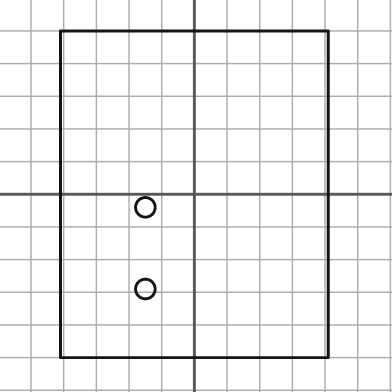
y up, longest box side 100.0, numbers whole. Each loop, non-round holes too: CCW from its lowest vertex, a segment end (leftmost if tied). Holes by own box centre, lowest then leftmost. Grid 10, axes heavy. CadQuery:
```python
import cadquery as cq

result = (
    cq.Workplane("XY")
    .moveTo(-41.0, -50.0)
    .lineTo(41.0, -50.0)
    .lineTo(41.0, 50.0)
    .lineTo(-41.0, 50.0)
    .close()
    .moveTo(-15.0, -29.0)
    .circle(3.0)
    .moveTo(-15.0, -4.0)
    .circle(3.0)
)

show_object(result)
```